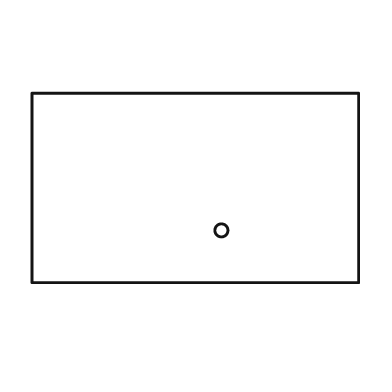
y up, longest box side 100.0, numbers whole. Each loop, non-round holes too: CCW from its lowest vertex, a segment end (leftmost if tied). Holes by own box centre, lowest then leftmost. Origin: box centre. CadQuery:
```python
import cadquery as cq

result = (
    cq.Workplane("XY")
    .moveTo(-50.0, -29.0)
    .lineTo(50.0, -29.0)
    .lineTo(50.0, 29.0)
    .lineTo(-50.0, 29.0)
    .close()
    .moveTo(8.0, -13.0)
    .circle(2.0)
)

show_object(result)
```